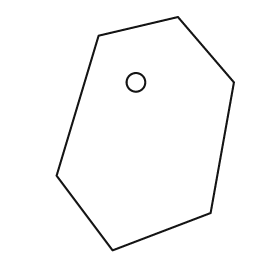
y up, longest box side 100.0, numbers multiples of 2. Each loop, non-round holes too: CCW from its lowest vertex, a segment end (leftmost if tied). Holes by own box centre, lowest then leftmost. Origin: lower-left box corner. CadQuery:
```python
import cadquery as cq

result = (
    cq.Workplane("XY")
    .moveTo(24.0, 0.0)
    .lineTo(66.0, 16.0)
    .lineTo(76.0, 72.0)
    .lineTo(52.0, 100.0)
    .lineTo(18.0, 92.0)
    .lineTo(0.0, 32.0)
    .close()
    .moveTo(34.0, 72.0)
    .circle(4.0)
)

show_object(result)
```